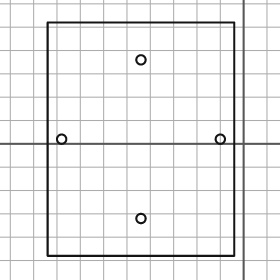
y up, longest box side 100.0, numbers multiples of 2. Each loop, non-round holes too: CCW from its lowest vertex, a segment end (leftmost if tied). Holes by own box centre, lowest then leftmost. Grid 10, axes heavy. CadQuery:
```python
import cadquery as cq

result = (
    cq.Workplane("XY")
    .moveTo(-84.0, -48.0)
    .lineTo(-4.0, -48.0)
    .lineTo(-4.0, 52.0)
    .lineTo(-84.0, 52.0)
    .close()
    .moveTo(-44.0, -32.0)
    .circle(2.0)
    .moveTo(-78.0, 2.0)
    .circle(2.0)
    .moveTo(-10.0, 2.0)
    .circle(2.0)
    .moveTo(-44.0, 36.0)
    .circle(2.0)
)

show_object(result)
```